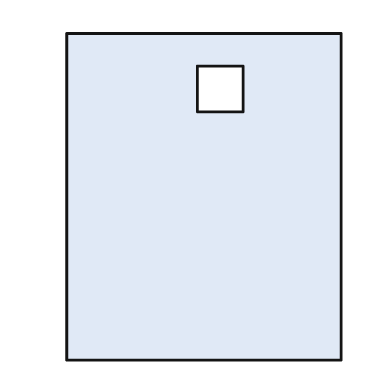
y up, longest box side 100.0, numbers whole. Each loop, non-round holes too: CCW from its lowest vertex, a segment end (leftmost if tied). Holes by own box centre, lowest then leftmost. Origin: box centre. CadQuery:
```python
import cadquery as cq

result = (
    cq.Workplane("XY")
    .moveTo(-42.0, -50.0)
    .lineTo(42.0, -50.0)
    .lineTo(42.0, 50.0)
    .lineTo(-42.0, 50.0)
    .close()
    .moveTo(-2.0, 26.0)
    .lineTo(12.0, 26.0)
    .lineTo(12.0, 40.0)
    .lineTo(-2.0, 40.0)
    .close()
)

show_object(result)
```